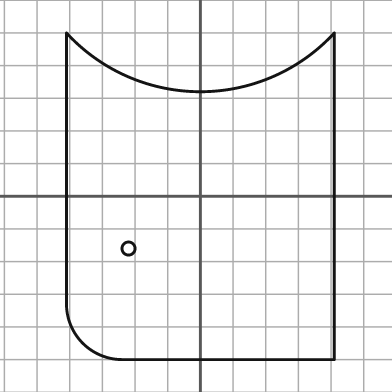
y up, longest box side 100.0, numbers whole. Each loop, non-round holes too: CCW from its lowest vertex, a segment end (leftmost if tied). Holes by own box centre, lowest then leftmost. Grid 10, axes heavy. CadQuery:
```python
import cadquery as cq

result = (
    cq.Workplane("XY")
    .moveTo(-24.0, -50.0)
    .lineTo(41.0, -50.0)
    .lineTo(41.0, 50.0)
    .threePointArc((0.0, 32.0), (-41.0, 50.0))
    .lineTo(-41.0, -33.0)
    .threePointArc((-36.0, -45.0), (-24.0, -50.0))
    .close()
    .moveTo(-22.0, -16.0)
    .circle(2.0)
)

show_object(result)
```